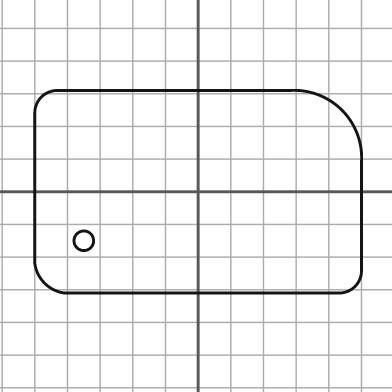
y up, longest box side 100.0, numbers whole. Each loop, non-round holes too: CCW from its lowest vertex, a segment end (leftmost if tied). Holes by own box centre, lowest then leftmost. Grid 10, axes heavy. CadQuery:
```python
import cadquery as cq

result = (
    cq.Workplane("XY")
    .moveTo(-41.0, -31.0)
    .lineTo(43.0, -31.0)
    .threePointArc((48.0, -29.0), (50.0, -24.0))
    .lineTo(50.0, 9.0)
    .threePointArc((44.0, 25.0), (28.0, 31.0))
    .lineTo(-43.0, 31.0)
    .threePointArc((-48.0, 29.0), (-50.0, 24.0))
    .lineTo(-50.0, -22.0)
    .threePointArc((-47.0, -28.0), (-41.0, -31.0))
    .close()
    .moveTo(-35.0, -15.0)
    .circle(3.0)
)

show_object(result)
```